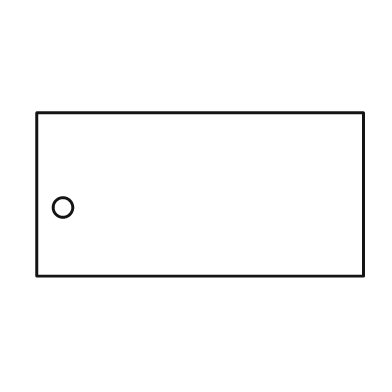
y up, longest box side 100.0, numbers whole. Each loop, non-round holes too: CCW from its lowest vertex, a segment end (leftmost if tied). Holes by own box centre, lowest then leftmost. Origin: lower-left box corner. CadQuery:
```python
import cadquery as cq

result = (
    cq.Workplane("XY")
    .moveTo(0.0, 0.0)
    .lineTo(100.0, 0.0)
    .lineTo(100.0, 50.0)
    .lineTo(0.0, 50.0)
    .close()
    .moveTo(8.0, 21.0)
    .circle(3.0)
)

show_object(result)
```